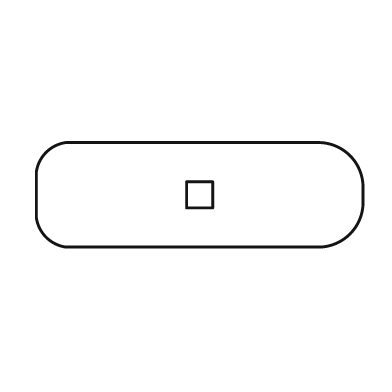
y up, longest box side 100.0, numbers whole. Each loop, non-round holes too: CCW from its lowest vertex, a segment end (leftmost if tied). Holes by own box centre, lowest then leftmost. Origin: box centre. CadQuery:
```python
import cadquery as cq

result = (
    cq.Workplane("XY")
    .moveTo(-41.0, -16.0)
    .lineTo(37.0, -16.0)
    .threePointArc((46.0, -12.0), (50.0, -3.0))
    .lineTo(50.0, 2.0)
    .threePointArc((46.0, 12.0), (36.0, 16.0))
    .lineTo(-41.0, 16.0)
    .threePointArc((-47.0, 13.0), (-50.0, 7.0))
    .lineTo(-50.0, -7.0)
    .threePointArc((-47.0, -13.0), (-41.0, -16.0))
    .close()
    .moveTo(-4.0, -4.0)
    .lineTo(4.0, -4.0)
    .lineTo(4.0, 4.0)
    .lineTo(-4.0, 4.0)
    .close()
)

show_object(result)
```